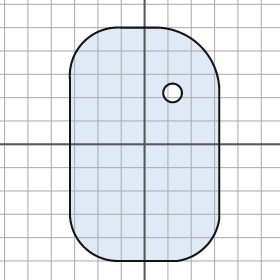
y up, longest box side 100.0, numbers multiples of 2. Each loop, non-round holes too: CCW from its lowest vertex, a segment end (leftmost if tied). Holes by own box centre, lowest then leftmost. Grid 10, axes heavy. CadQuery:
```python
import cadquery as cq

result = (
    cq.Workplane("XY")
    .moveTo(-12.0, -50.0)
    .lineTo(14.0, -50.0)
    .threePointArc((26.0, -44.0), (32.0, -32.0))
    .lineTo(32.0, 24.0)
    .threePointArc((24.0, 42.0), (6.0, 50.0))
    .lineTo(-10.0, 50.0)
    .threePointArc((-26.0, 44.0), (-32.0, 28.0))
    .lineTo(-32.0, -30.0)
    .threePointArc((-26.0, -44.0), (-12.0, -50.0))
    .close()
    .moveTo(12.0, 22.0)
    .circle(4.0)
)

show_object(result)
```